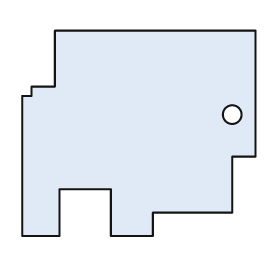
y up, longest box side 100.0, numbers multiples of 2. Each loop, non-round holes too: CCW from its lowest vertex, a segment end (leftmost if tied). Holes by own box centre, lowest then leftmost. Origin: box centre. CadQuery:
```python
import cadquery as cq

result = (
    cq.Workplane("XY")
    .moveTo(-50.0, -44.0)
    .lineTo(-34.0, -44.0)
    .lineTo(-34.0, -24.0)
    .lineTo(-12.0, -24.0)
    .lineTo(-12.0, -44.0)
    .lineTo(6.0, -44.0)
    .lineTo(6.0, -34.0)
    .lineTo(40.0, -34.0)
    .lineTo(40.0, -10.0)
    .lineTo(50.0, -10.0)
    .lineTo(50.0, 44.0)
    .lineTo(-36.0, 44.0)
    .lineTo(-36.0, 20.0)
    .lineTo(-46.0, 20.0)
    .lineTo(-46.0, 16.0)
    .lineTo(-50.0, 16.0)
    .close()
    .moveTo(40.0, 8.0)
    .circle(4.0)
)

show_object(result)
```